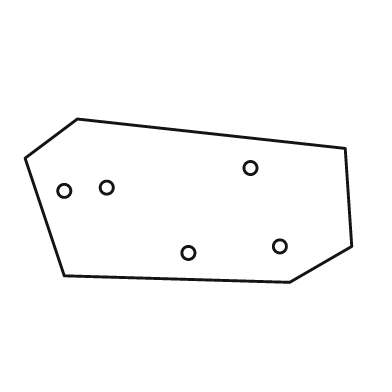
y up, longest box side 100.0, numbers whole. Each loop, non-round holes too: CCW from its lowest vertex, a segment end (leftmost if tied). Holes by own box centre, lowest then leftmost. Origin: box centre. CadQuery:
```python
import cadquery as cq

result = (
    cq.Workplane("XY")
    .moveTo(31.0, -25.0)
    .lineTo(50.0, -14.0)
    .lineTo(48.0, 16.0)
    .lineTo(-34.0, 25.0)
    .lineTo(-50.0, 13.0)
    .lineTo(-38.0, -23.0)
    .close()
    .moveTo(0.0, -16.0)
    .circle(2.0)
    .moveTo(28.0, -14.0)
    .circle(2.0)
    .moveTo(-38.0, 3.0)
    .circle(2.0)
    .moveTo(-25.0, 4.0)
    .circle(2.0)
    .moveTo(19.0, 10.0)
    .circle(2.0)
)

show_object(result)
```